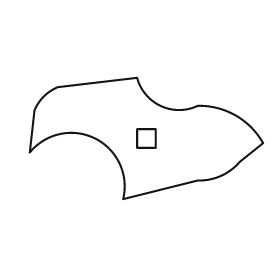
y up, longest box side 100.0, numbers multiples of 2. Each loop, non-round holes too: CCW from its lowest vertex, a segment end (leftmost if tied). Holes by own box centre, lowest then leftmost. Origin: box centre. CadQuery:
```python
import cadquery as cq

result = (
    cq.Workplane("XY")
    .moveTo(-10.0, -26.0)
    .lineTo(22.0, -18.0)
    .threePointArc((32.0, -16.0), (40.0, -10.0))
    .lineTo(50.0, -2.0)
    .threePointArc((38.0, 10.0), (22.0, 14.0))
    .threePointArc((6.0, 14.0), (-4.0, 26.0))
    .lineTo(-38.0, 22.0)
    .threePointArc((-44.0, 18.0), (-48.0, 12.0))
    .lineTo(-50.0, -6.0)
    .threePointArc((-22.0, 0.0), (-10.0, -26.0))
    .close()
    .moveTo(-4.0, -4.0)
    .lineTo(4.0, -4.0)
    .lineTo(4.0, 4.0)
    .lineTo(-4.0, 4.0)
    .close()
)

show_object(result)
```